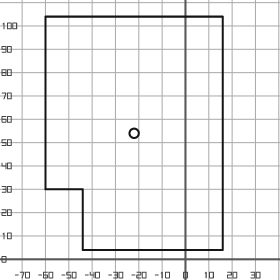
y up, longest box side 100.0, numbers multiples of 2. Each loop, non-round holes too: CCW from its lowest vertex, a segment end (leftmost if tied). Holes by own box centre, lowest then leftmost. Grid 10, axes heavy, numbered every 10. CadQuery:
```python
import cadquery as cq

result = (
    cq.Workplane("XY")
    .moveTo(-44.0, 4.0)
    .lineTo(16.0, 4.0)
    .lineTo(16.0, 104.0)
    .lineTo(-60.0, 104.0)
    .lineTo(-60.0, 30.0)
    .lineTo(-44.0, 30.0)
    .close()
    .moveTo(-22.0, 54.0)
    .circle(2.0)
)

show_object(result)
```